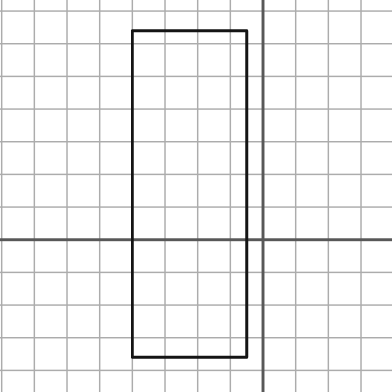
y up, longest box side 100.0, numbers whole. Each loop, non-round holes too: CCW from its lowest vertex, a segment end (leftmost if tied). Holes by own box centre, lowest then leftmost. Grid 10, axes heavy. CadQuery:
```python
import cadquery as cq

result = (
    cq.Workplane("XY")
    .moveTo(-40.0, -36.0)
    .lineTo(-5.0, -36.0)
    .lineTo(-5.0, 64.0)
    .lineTo(-40.0, 64.0)
    .close()
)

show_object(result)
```